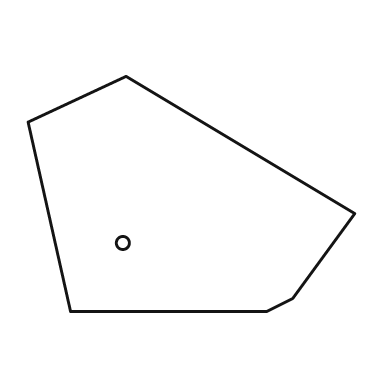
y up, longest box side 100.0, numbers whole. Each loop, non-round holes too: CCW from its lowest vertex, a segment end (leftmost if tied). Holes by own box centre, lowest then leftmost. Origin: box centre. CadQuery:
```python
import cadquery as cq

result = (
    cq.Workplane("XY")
    .moveTo(-37.0, -36.0)
    .lineTo(23.0, -36.0)
    .lineTo(31.0, -32.0)
    .lineTo(50.0, -6.0)
    .lineTo(-20.0, 36.0)
    .lineTo(-50.0, 22.0)
    .close()
    .moveTo(-21.0, -15.0)
    .circle(2.0)
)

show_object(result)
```